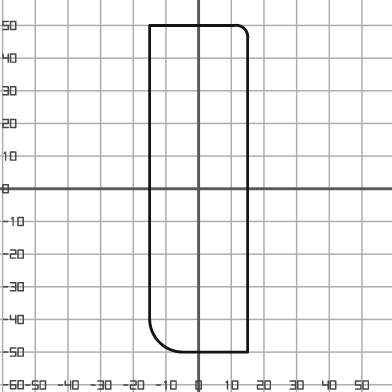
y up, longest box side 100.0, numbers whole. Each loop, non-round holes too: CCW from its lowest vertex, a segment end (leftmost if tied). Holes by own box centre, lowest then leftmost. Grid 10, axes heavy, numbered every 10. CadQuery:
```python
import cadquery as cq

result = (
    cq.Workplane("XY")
    .moveTo(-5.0, -50.0)
    .lineTo(15.0, -50.0)
    .lineTo(15.0, 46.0)
    .threePointArc((14.0, 49.0), (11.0, 50.0))
    .lineTo(-15.0, 50.0)
    .lineTo(-15.0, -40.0)
    .threePointArc((-12.0, -47.0), (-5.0, -50.0))
    .close()
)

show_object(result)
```